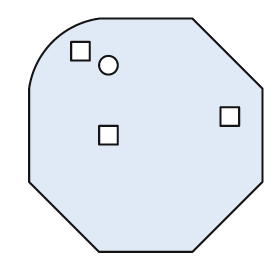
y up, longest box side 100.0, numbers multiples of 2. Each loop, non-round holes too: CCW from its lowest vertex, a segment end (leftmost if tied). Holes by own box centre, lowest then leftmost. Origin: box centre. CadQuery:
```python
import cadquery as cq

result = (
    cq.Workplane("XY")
    .moveTo(-20.0, -50.0)
    .lineTo(20.0, -50.0)
    .lineTo(50.0, -20.0)
    .lineTo(50.0, 20.0)
    .lineTo(20.0, 50.0)
    .lineTo(-20.0, 50.0)
    .threePointArc((-40.0, 40.0), (-50.0, 20.0))
    .lineTo(-50.0, -20.0)
    .close()
    .moveTo(-20.0, -4.0)
    .lineTo(-12.0, -4.0)
    .lineTo(-12.0, 4.0)
    .lineTo(-20.0, 4.0)
    .close()
    .moveTo(32.0, 4.0)
    .lineTo(40.0, 4.0)
    .lineTo(40.0, 12.0)
    .lineTo(32.0, 12.0)
    .close()
    .moveTo(-16.0, 30.0)
    .circle(4.0)
    .moveTo(-32.0, 32.0)
    .lineTo(-24.0, 32.0)
    .lineTo(-24.0, 40.0)
    .lineTo(-32.0, 40.0)
    .close()
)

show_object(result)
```